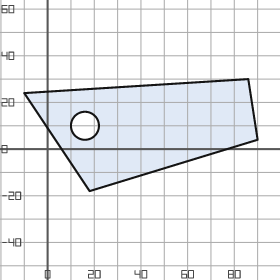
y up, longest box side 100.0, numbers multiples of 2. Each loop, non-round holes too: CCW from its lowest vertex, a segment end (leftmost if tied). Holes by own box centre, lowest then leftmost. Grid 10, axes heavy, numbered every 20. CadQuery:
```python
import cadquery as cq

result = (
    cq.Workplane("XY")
    .moveTo(18.0, -18.0)
    .lineTo(90.0, 4.0)
    .lineTo(86.0, 30.0)
    .lineTo(-10.0, 24.0)
    .close()
    .moveTo(16.0, 10.0)
    .circle(6.0)
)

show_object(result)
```